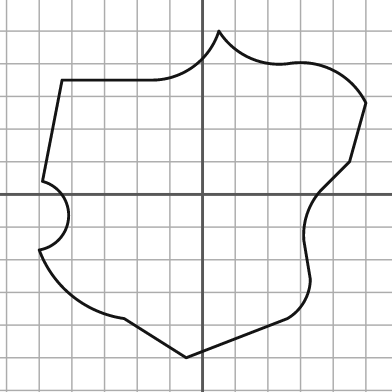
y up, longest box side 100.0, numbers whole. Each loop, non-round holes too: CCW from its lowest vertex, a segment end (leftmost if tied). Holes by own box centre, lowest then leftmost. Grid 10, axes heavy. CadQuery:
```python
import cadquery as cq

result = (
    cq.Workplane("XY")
    .moveTo(-5.0, -50.0)
    .lineTo(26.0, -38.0)
    .threePointArc((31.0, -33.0), (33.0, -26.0))
    .lineTo(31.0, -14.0)
    .threePointArc((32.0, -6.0), (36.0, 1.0))
    .lineTo(45.0, 10.0)
    .lineTo(50.0, 28.0)
    .threePointArc((40.0, 38.0), (26.0, 40.0))
    .threePointArc((14.0, 42.0), (5.0, 50.0))
    .threePointArc((-3.0, 39.0), (-16.0, 35.0))
    .lineTo(-43.0, 35.0)
    .lineTo(-49.0, 4.0)
    .threePointArc((-41.0, -7.0), (-50.0, -17.0))
    .threePointArc((-40.0, -31.0), (-24.0, -38.0))
    .close()
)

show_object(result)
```